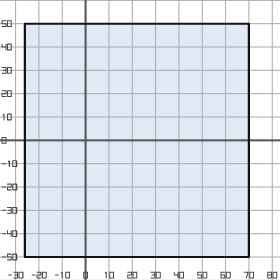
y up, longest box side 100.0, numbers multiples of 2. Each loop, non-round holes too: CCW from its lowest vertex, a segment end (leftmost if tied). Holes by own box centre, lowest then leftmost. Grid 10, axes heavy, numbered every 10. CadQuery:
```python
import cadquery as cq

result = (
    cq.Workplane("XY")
    .moveTo(-26.0, -50.0)
    .lineTo(70.0, -50.0)
    .lineTo(70.0, 50.0)
    .lineTo(-26.0, 50.0)
    .close()
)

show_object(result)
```